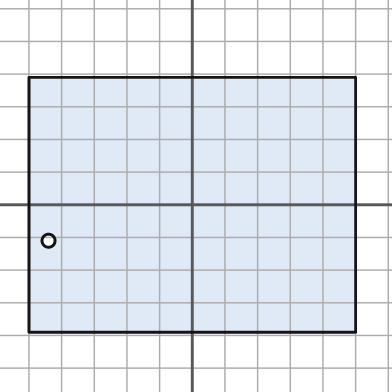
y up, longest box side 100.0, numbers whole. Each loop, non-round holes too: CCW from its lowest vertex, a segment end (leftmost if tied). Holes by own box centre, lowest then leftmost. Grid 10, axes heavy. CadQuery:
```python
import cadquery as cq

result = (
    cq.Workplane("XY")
    .moveTo(-50.0, -39.0)
    .lineTo(50.0, -39.0)
    .lineTo(50.0, 39.0)
    .lineTo(-50.0, 39.0)
    .close()
    .moveTo(-44.0, -11.0)
    .circle(2.0)
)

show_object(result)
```